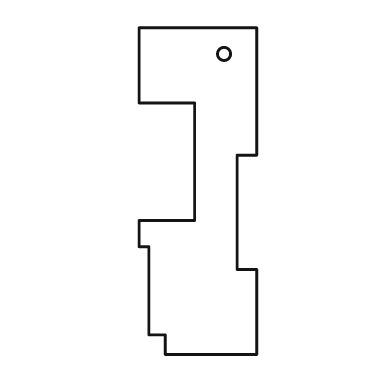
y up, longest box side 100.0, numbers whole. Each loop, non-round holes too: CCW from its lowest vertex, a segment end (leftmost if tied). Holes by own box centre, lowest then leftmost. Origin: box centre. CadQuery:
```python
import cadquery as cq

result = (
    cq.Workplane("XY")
    .moveTo(-10.0, -50.0)
    .lineTo(18.0, -50.0)
    .lineTo(18.0, -24.0)
    .lineTo(12.0, -24.0)
    .lineTo(12.0, 11.0)
    .lineTo(18.0, 11.0)
    .lineTo(18.0, 50.0)
    .lineTo(-18.0, 50.0)
    .lineTo(-18.0, 27.0)
    .lineTo(-1.0, 27.0)
    .lineTo(-1.0, -9.0)
    .lineTo(-18.0, -9.0)
    .lineTo(-18.0, -17.0)
    .lineTo(-15.0, -17.0)
    .lineTo(-15.0, -44.0)
    .lineTo(-10.0, -44.0)
    .close()
    .moveTo(8.0, 42.0)
    .circle(2.0)
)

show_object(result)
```